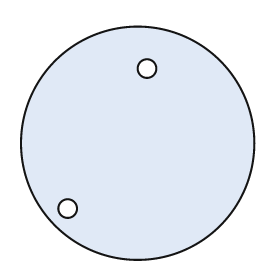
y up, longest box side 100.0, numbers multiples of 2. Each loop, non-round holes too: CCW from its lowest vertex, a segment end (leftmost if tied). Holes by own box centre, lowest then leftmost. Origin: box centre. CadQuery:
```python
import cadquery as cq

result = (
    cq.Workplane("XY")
    .moveTo(0.0, 0.0)
    .circle(50.0)
    .moveTo(-30.0, -28.0)
    .circle(4.0)
    .moveTo(4.0, 32.0)
    .circle(4.0)
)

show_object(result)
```